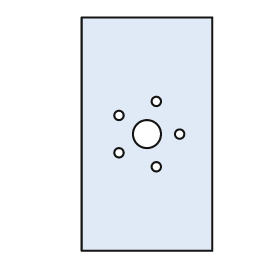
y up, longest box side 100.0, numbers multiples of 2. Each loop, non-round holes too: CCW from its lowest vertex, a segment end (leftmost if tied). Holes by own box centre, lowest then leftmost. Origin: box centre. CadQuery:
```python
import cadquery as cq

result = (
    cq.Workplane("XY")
    .moveTo(-28.0, -50.0)
    .lineTo(28.0, -50.0)
    .lineTo(28.0, 50.0)
    .lineTo(-28.0, 50.0)
    .close()
    .moveTo(4.0, -14.0)
    .circle(2.0)
    .moveTo(-12.0, -8.0)
    .circle(2.0)
    .moveTo(0.0, 0.0)
    .circle(6.0)
    .moveTo(14.0, 0.0)
    .circle(2.0)
    .moveTo(-12.0, 8.0)
    .circle(2.0)
    .moveTo(4.0, 14.0)
    .circle(2.0)
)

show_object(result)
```